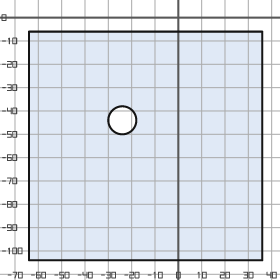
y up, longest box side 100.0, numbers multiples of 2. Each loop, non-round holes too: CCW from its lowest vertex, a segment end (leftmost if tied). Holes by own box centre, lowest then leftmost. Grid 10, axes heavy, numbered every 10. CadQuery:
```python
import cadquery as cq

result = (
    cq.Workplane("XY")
    .moveTo(-64.0, -104.0)
    .lineTo(36.0, -104.0)
    .lineTo(36.0, -6.0)
    .lineTo(-64.0, -6.0)
    .close()
    .moveTo(-24.0, -44.0)
    .circle(6.0)
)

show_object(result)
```